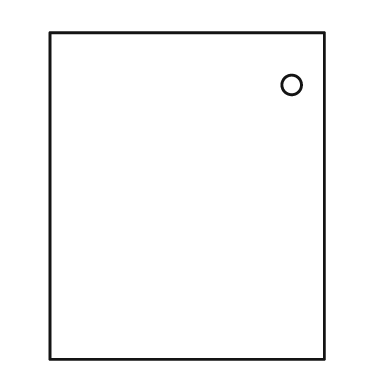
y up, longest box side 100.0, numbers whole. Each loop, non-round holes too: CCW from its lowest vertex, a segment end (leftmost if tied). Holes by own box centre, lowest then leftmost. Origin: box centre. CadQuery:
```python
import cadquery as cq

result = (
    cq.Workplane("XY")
    .moveTo(-42.0, -50.0)
    .lineTo(42.0, -50.0)
    .lineTo(42.0, 50.0)
    .lineTo(-42.0, 50.0)
    .close()
    .moveTo(32.0, 34.0)
    .circle(3.0)
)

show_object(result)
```